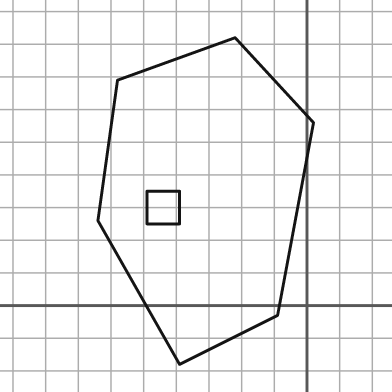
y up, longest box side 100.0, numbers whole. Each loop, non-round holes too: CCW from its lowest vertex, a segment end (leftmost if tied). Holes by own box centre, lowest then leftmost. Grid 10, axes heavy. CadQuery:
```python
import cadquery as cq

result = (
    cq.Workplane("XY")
    .moveTo(-39.0, -18.0)
    .lineTo(-9.0, -3.0)
    .lineTo(2.0, 56.0)
    .lineTo(-22.0, 82.0)
    .lineTo(-58.0, 69.0)
    .lineTo(-64.0, 26.0)
    .close()
    .moveTo(-49.0, 25.0)
    .lineTo(-39.0, 25.0)
    .lineTo(-39.0, 35.0)
    .lineTo(-49.0, 35.0)
    .close()
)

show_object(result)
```